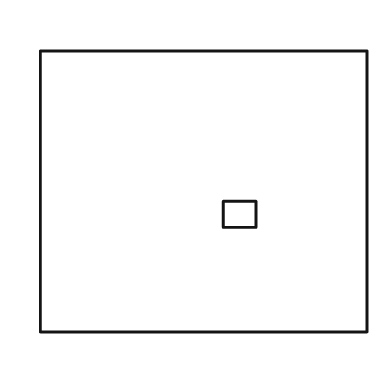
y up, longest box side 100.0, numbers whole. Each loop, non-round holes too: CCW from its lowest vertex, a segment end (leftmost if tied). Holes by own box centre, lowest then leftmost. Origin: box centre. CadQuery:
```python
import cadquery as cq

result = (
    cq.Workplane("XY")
    .moveTo(-50.0, -43.0)
    .lineTo(50.0, -43.0)
    .lineTo(50.0, 43.0)
    .lineTo(-50.0, 43.0)
    .close()
    .moveTo(6.0, -11.0)
    .lineTo(16.0, -11.0)
    .lineTo(16.0, -3.0)
    .lineTo(6.0, -3.0)
    .close()
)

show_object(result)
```